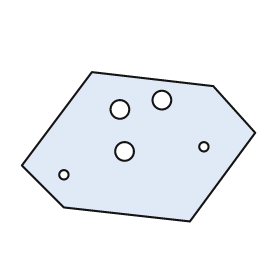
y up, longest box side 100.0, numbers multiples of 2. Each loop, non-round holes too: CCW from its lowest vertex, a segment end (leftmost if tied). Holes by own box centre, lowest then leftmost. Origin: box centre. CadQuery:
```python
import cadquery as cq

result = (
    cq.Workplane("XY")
    .moveTo(22.0, -32.0)
    .lineTo(50.0, 6.0)
    .lineTo(32.0, 26.0)
    .lineTo(-20.0, 32.0)
    .lineTo(-50.0, -8.0)
    .lineTo(-32.0, -26.0)
    .close()
    .moveTo(-32.0, -12.0)
    .circle(2.0)
    .moveTo(-6.0, -2.0)
    .circle(4.0)
    .moveTo(28.0, 0.0)
    .circle(2.0)
    .moveTo(-8.0, 16.0)
    .circle(4.0)
    .moveTo(10.0, 20.0)
    .circle(4.0)
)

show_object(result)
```